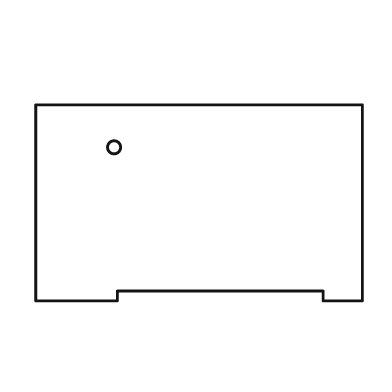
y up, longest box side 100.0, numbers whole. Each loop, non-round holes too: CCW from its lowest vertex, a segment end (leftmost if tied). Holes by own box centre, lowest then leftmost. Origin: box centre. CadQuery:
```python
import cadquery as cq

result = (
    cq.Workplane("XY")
    .moveTo(-50.0, -30.0)
    .lineTo(-25.0, -30.0)
    .lineTo(-25.0, -27.0)
    .lineTo(38.0, -27.0)
    .lineTo(38.0, -30.0)
    .lineTo(50.0, -30.0)
    .lineTo(50.0, 30.0)
    .lineTo(-50.0, 30.0)
    .close()
    .moveTo(-26.0, 17.0)
    .circle(2.0)
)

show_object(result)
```